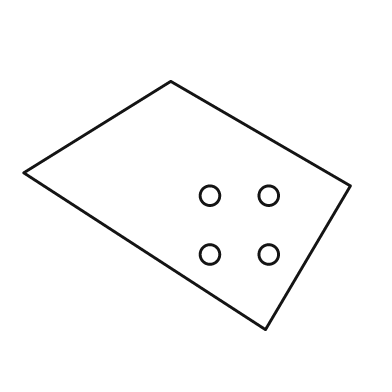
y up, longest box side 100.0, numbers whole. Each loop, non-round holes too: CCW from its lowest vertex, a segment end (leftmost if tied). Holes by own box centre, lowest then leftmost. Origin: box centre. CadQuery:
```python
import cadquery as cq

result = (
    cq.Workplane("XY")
    .moveTo(24.0, -38.0)
    .lineTo(50.0, 6.0)
    .lineTo(-5.0, 38.0)
    .lineTo(-50.0, 10.0)
    .close()
    .moveTo(7.0, -15.0)
    .circle(3.0)
    .moveTo(25.0, -15.0)
    .circle(3.0)
    .moveTo(7.0, 3.0)
    .circle(3.0)
    .moveTo(25.0, 3.0)
    .circle(3.0)
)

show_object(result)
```